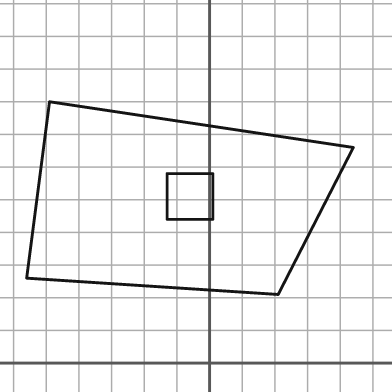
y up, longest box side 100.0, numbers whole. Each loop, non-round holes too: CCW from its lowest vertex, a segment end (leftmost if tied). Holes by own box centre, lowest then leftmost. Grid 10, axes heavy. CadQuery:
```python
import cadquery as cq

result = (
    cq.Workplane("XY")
    .moveTo(21.0, 21.0)
    .lineTo(44.0, 66.0)
    .lineTo(-49.0, 80.0)
    .lineTo(-56.0, 26.0)
    .close()
    .moveTo(-13.0, 44.0)
    .lineTo(1.0, 44.0)
    .lineTo(1.0, 58.0)
    .lineTo(-13.0, 58.0)
    .close()
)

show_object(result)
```